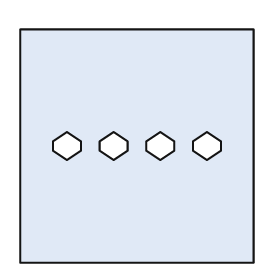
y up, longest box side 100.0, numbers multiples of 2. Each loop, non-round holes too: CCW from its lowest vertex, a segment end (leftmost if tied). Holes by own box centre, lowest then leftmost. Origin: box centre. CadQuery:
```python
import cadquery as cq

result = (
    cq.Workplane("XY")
    .moveTo(-50.0, -50.0)
    .lineTo(50.0, -50.0)
    .lineTo(50.0, 50.0)
    .lineTo(-50.0, 50.0)
    .close()
    .moveTo(-30.0, -6.0)
    .lineTo(-24.0, -2.0)
    .lineTo(-24.0, 2.0)
    .lineTo(-30.0, 6.0)
    .lineTo(-36.0, 2.0)
    .lineTo(-36.0, -2.0)
    .close()
    .moveTo(-10.0, -6.0)
    .lineTo(-4.0, -2.0)
    .lineTo(-4.0, 2.0)
    .lineTo(-10.0, 6.0)
    .lineTo(-16.0, 2.0)
    .lineTo(-16.0, -2.0)
    .close()
    .moveTo(10.0, -6.0)
    .lineTo(16.0, -2.0)
    .lineTo(16.0, 2.0)
    .lineTo(10.0, 6.0)
    .lineTo(4.0, 2.0)
    .lineTo(4.0, -2.0)
    .close()
    .moveTo(30.0, -6.0)
    .lineTo(36.0, -2.0)
    .lineTo(36.0, 2.0)
    .lineTo(30.0, 6.0)
    .lineTo(24.0, 2.0)
    .lineTo(24.0, -2.0)
    .close()
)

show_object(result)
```